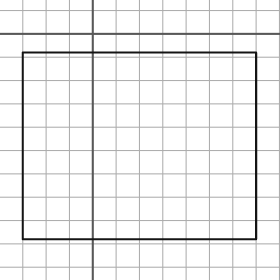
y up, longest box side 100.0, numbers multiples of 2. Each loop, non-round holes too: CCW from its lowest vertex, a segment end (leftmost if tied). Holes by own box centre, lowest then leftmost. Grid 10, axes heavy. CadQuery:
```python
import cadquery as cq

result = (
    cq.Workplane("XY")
    .moveTo(-30.0, -88.0)
    .lineTo(70.0, -88.0)
    .lineTo(70.0, -8.0)
    .lineTo(-30.0, -8.0)
    .close()
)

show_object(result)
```